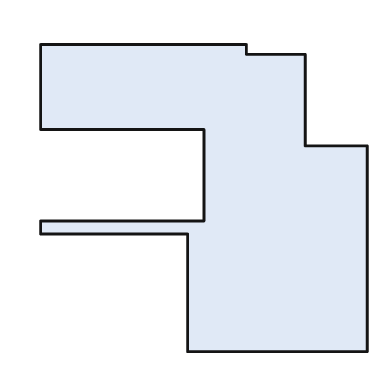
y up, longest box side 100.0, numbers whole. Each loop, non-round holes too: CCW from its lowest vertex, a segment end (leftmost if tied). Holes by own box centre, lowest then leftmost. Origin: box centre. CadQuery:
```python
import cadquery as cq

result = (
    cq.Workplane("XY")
    .moveTo(-5.0, -47.0)
    .lineTo(50.0, -47.0)
    .lineTo(50.0, 16.0)
    .lineTo(31.0, 16.0)
    .lineTo(31.0, 44.0)
    .lineTo(13.0, 44.0)
    .lineTo(13.0, 47.0)
    .lineTo(-50.0, 47.0)
    .lineTo(-50.0, 21.0)
    .lineTo(0.0, 21.0)
    .lineTo(0.0, -7.0)
    .lineTo(-50.0, -7.0)
    .lineTo(-50.0, -11.0)
    .lineTo(-5.0, -11.0)
    .close()
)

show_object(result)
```